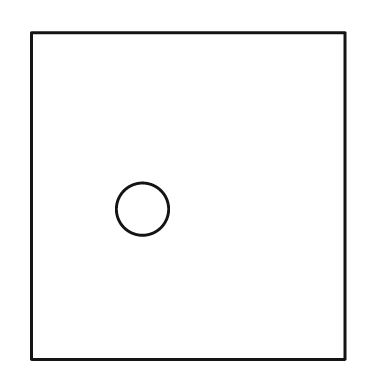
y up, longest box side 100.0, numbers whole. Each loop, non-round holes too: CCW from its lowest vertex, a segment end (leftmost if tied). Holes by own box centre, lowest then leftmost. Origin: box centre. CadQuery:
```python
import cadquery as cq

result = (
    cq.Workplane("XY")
    .moveTo(-48.0, -50.0)
    .lineTo(48.0, -50.0)
    .lineTo(48.0, 50.0)
    .lineTo(-48.0, 50.0)
    .close()
    .moveTo(-14.0, -4.0)
    .circle(8.0)
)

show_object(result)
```